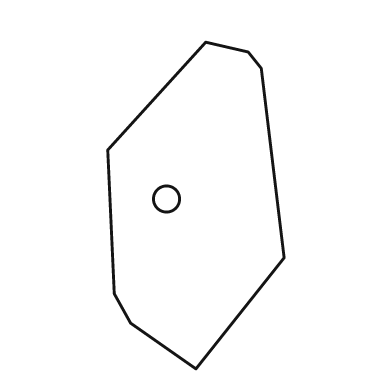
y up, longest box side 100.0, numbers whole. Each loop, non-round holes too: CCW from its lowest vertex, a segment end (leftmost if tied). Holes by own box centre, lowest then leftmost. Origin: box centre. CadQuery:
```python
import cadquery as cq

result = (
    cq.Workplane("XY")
    .moveTo(0.0, -50.0)
    .lineTo(27.0, -16.0)
    .lineTo(20.0, 42.0)
    .lineTo(16.0, 47.0)
    .lineTo(3.0, 50.0)
    .lineTo(-27.0, 17.0)
    .lineTo(-25.0, -27.0)
    .lineTo(-20.0, -36.0)
    .close()
    .moveTo(-9.0, 2.0)
    .circle(4.0)
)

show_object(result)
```